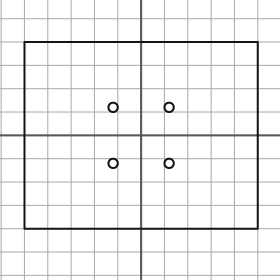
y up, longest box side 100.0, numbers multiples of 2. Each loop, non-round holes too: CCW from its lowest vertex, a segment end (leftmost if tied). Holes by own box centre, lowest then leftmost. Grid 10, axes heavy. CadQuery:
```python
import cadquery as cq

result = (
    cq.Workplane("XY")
    .moveTo(-50.0, -40.0)
    .lineTo(50.0, -40.0)
    .lineTo(50.0, 40.0)
    .lineTo(-50.0, 40.0)
    .close()
    .moveTo(-12.0, -12.0)
    .circle(2.0)
    .moveTo(12.0, -12.0)
    .circle(2.0)
    .moveTo(-12.0, 12.0)
    .circle(2.0)
    .moveTo(12.0, 12.0)
    .circle(2.0)
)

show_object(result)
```